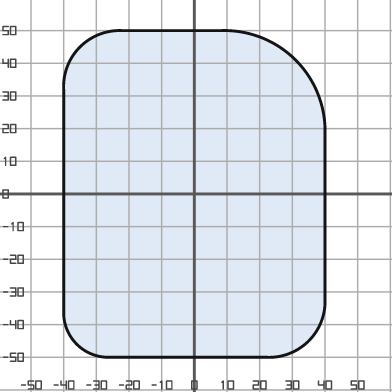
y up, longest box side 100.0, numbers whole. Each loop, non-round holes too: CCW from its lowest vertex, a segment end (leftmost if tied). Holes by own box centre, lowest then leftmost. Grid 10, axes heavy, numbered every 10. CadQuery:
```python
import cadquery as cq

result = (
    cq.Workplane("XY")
    .moveTo(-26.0, -50.0)
    .lineTo(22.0, -50.0)
    .threePointArc((35.0, -45.0), (40.0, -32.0))
    .lineTo(40.0, 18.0)
    .threePointArc((31.0, 41.0), (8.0, 50.0))
    .lineTo(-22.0, 50.0)
    .threePointArc((-35.0, 45.0), (-40.0, 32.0))
    .lineTo(-40.0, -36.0)
    .threePointArc((-36.0, -46.0), (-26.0, -50.0))
    .close()
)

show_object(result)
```